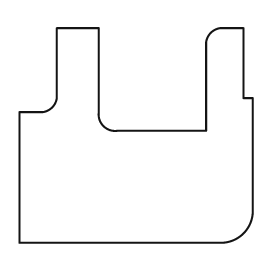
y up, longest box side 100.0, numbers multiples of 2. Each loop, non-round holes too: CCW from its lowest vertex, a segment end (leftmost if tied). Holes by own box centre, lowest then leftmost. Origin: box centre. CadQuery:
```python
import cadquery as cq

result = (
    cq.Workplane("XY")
    .moveTo(-50.0, -46.0)
    .lineTo(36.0, -46.0)
    .threePointArc((46.0, -42.0), (50.0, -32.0))
    .lineTo(50.0, 16.0)
    .lineTo(46.0, 16.0)
    .lineTo(46.0, 46.0)
    .lineTo(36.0, 46.0)
    .threePointArc((32.0, 44.0), (30.0, 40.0))
    .lineTo(30.0, 2.0)
    .lineTo(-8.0, 2.0)
    .threePointArc((-14.0, 4.0), (-16.0, 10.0))
    .lineTo(-16.0, 46.0)
    .lineTo(-34.0, 46.0)
    .lineTo(-34.0, 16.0)
    .threePointArc((-36.0, 12.0), (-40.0, 10.0))
    .lineTo(-50.0, 10.0)
    .close()
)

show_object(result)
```